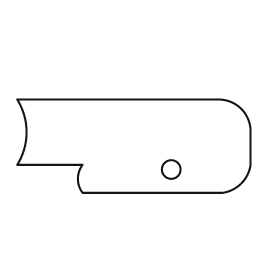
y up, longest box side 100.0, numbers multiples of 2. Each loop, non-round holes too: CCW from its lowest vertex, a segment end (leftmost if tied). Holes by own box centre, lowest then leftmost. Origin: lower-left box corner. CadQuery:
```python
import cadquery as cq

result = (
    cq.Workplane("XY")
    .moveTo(28.0, 0.0)
    .lineTo(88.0, 0.0)
    .threePointArc((96.0, 4.0), (100.0, 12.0))
    .lineTo(100.0, 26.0)
    .threePointArc((96.0, 36.0), (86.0, 40.0))
    .lineTo(0.0, 40.0)
    .threePointArc((4.0, 26.0), (0.0, 12.0))
    .lineTo(28.0, 12.0)
    .threePointArc((26.0, 6.0), (28.0, 0.0))
    .close()
    .moveTo(66.0, 10.0)
    .circle(4.0)
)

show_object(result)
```